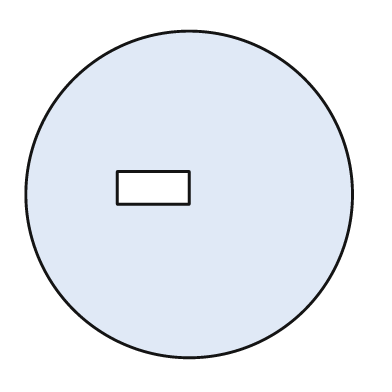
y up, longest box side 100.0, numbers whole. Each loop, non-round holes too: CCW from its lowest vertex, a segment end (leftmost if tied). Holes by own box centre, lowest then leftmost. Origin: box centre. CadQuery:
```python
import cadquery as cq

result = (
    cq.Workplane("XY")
    .moveTo(0.0, 0.0)
    .circle(50.0)
    .moveTo(-22.0, -3.0)
    .lineTo(0.0, -3.0)
    .lineTo(0.0, 7.0)
    .lineTo(-22.0, 7.0)
    .close()
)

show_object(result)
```